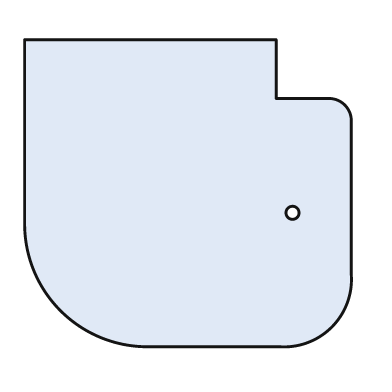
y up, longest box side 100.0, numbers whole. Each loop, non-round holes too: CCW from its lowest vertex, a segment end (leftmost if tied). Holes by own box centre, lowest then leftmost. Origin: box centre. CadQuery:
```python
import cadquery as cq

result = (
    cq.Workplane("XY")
    .moveTo(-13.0, -47.0)
    .lineTo(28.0, -47.0)
    .threePointArc((44.0, -41.0), (50.0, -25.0))
    .lineTo(50.0, 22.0)
    .threePointArc((48.0, 27.0), (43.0, 29.0))
    .lineTo(27.0, 29.0)
    .lineTo(27.0, 47.0)
    .lineTo(-50.0, 47.0)
    .lineTo(-50.0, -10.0)
    .threePointArc((-39.0, -36.0), (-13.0, -47.0))
    .close()
    .moveTo(32.0, -6.0)
    .circle(2.0)
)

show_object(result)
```